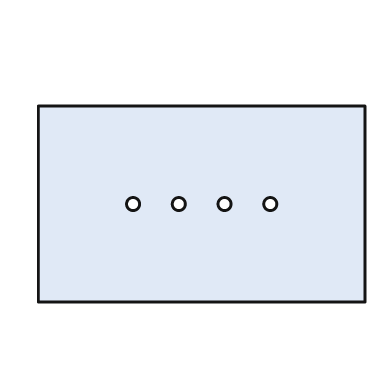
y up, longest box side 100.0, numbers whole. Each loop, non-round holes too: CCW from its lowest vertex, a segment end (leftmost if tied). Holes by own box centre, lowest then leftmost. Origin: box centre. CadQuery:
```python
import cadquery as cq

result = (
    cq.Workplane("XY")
    .moveTo(-50.0, -30.0)
    .lineTo(50.0, -30.0)
    .lineTo(50.0, 30.0)
    .lineTo(-50.0, 30.0)
    .close()
    .moveTo(-21.0, 0.0)
    .circle(2.0)
    .moveTo(-7.0, 0.0)
    .circle(2.0)
    .moveTo(7.0, 0.0)
    .circle(2.0)
    .moveTo(21.0, 0.0)
    .circle(2.0)
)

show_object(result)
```